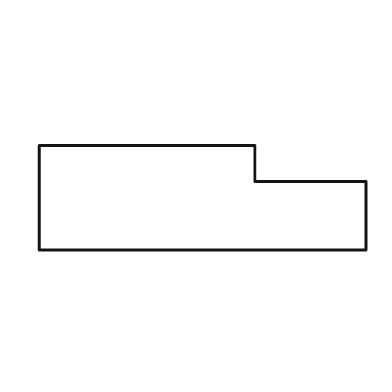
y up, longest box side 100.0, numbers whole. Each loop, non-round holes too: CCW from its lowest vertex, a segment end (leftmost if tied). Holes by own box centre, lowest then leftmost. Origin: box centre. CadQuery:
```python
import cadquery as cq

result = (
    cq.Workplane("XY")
    .moveTo(-50.0, -16.0)
    .lineTo(50.0, -16.0)
    .lineTo(50.0, 5.0)
    .lineTo(16.0, 5.0)
    .lineTo(16.0, 16.0)
    .lineTo(-50.0, 16.0)
    .close()
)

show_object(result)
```